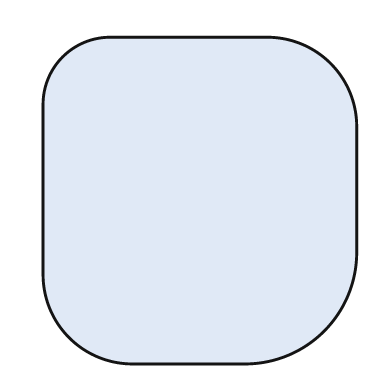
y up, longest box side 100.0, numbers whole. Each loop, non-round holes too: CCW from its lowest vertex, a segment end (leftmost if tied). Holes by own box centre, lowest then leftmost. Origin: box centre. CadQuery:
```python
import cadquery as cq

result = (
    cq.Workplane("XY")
    .moveTo(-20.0, -50.0)
    .lineTo(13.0, -50.0)
    .threePointArc((38.0, -40.0), (48.0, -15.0))
    .lineTo(48.0, 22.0)
    .threePointArc((40.0, 42.0), (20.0, 50.0))
    .lineTo(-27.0, 50.0)
    .threePointArc((-42.0, 44.0), (-48.0, 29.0))
    .lineTo(-48.0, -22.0)
    .threePointArc((-40.0, -42.0), (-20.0, -50.0))
    .close()
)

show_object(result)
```